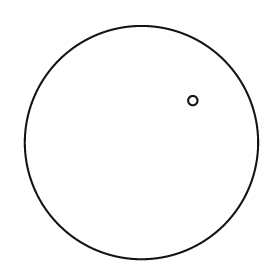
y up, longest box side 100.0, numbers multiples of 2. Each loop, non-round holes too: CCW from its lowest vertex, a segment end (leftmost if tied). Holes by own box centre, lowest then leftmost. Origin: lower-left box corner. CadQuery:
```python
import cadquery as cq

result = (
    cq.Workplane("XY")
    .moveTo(50.0, 50.0)
    .circle(50.0)
    .moveTo(72.0, 68.0)
    .circle(2.0)
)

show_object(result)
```